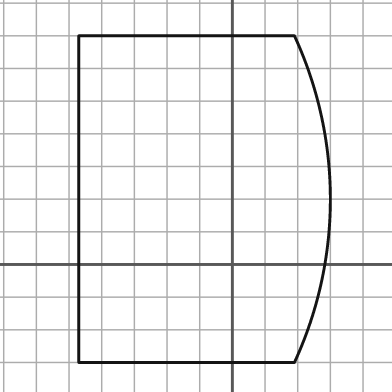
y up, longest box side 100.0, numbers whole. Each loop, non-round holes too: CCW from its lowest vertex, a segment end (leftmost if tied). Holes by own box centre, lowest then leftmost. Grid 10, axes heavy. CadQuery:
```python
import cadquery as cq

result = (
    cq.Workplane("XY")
    .moveTo(-47.0, -30.0)
    .lineTo(19.0, -30.0)
    .threePointArc((30.0, 20.0), (19.0, 70.0))
    .lineTo(-47.0, 70.0)
    .close()
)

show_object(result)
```